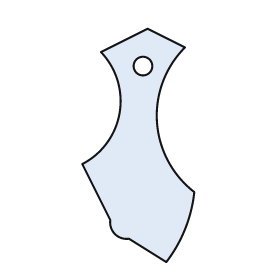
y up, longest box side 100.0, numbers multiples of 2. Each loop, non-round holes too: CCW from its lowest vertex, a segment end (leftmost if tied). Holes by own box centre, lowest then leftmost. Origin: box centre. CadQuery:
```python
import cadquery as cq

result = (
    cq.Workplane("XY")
    .moveTo(12.0, -50.0)
    .threePointArc((20.0, -36.0), (24.0, -20.0))
    .threePointArc((8.0, 10.0), (20.0, 42.0))
    .lineTo(4.0, 50.0)
    .lineTo(-16.0, 40.0)
    .threePointArc((-8.0, 14.0), (-24.0, -8.0))
    .lineTo(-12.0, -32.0)
    .threePointArc((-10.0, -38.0), (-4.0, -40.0))
    .close()
    .moveTo(2.0, 34.0)
    .circle(4.0)
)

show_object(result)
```